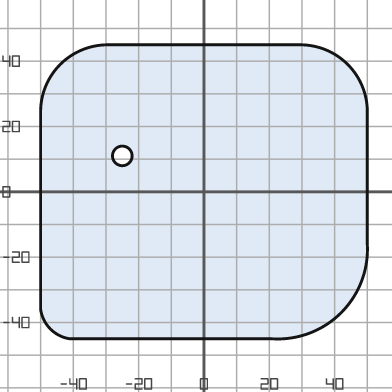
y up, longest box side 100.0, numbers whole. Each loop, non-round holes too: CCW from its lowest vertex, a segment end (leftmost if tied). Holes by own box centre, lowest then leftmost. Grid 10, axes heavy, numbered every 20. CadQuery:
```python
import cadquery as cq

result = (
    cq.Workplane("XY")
    .moveTo(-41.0, -45.0)
    .lineTo(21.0, -45.0)
    .threePointArc((42.0, -37.0), (50.0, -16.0))
    .lineTo(50.0, 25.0)
    .threePointArc((44.0, 39.0), (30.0, 45.0))
    .lineTo(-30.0, 45.0)
    .threePointArc((-44.0, 39.0), (-50.0, 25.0))
    .lineTo(-50.0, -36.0)
    .threePointArc((-47.0, -42.0), (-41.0, -45.0))
    .close()
    .moveTo(-25.0, 11.0)
    .circle(3.0)
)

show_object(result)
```